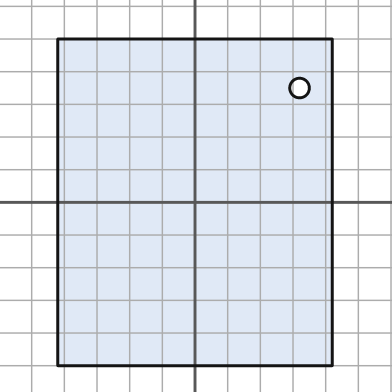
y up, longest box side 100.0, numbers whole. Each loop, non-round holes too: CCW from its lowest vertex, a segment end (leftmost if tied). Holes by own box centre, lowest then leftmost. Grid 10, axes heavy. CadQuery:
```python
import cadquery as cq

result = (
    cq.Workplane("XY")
    .moveTo(-42.0, -50.0)
    .lineTo(42.0, -50.0)
    .lineTo(42.0, 50.0)
    .lineTo(-42.0, 50.0)
    .close()
    .moveTo(32.0, 35.0)
    .circle(3.0)
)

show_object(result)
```